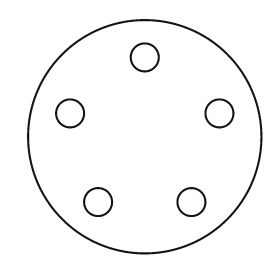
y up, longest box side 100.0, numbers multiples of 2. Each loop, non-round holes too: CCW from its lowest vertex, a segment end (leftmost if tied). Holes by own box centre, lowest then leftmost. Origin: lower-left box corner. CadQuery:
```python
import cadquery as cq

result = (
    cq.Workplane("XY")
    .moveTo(50.0, 50.0)
    .circle(50.0)
    .moveTo(30.0, 22.0)
    .circle(6.0)
    .moveTo(70.0, 22.0)
    .circle(6.0)
    .moveTo(18.0, 60.0)
    .circle(6.0)
    .moveTo(82.0, 60.0)
    .circle(6.0)
    .moveTo(50.0, 84.0)
    .circle(6.0)
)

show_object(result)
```